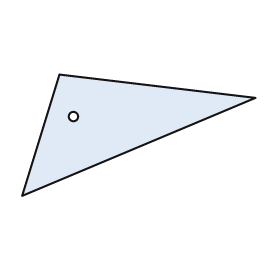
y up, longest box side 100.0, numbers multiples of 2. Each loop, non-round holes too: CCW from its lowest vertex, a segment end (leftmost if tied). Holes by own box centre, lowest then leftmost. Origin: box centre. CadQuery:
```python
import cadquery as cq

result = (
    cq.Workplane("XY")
    .moveTo(-50.0, -26.0)
    .lineTo(50.0, 16.0)
    .lineTo(-34.0, 26.0)
    .close()
    .moveTo(-28.0, 8.0)
    .circle(2.0)
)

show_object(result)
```